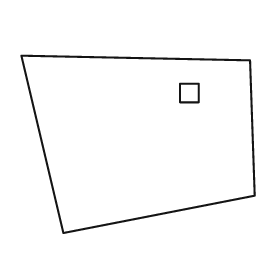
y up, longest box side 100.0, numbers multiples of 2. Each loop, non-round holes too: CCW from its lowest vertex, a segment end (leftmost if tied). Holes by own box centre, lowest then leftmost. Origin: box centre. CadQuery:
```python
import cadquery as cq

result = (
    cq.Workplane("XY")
    .moveTo(-32.0, -38.0)
    .lineTo(50.0, -22.0)
    .lineTo(48.0, 36.0)
    .lineTo(-50.0, 38.0)
    .close()
    .moveTo(18.0, 18.0)
    .lineTo(26.0, 18.0)
    .lineTo(26.0, 26.0)
    .lineTo(18.0, 26.0)
    .close()
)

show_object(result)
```